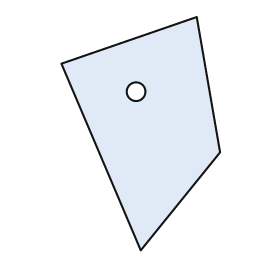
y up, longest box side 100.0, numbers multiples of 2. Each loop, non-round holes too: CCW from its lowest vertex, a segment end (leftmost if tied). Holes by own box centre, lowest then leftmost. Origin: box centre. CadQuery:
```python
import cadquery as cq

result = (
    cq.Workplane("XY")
    .moveTo(0.0, -50.0)
    .lineTo(34.0, -8.0)
    .lineTo(24.0, 50.0)
    .lineTo(-34.0, 30.0)
    .close()
    .moveTo(-2.0, 18.0)
    .circle(4.0)
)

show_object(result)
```